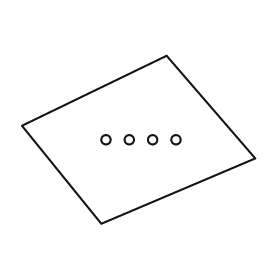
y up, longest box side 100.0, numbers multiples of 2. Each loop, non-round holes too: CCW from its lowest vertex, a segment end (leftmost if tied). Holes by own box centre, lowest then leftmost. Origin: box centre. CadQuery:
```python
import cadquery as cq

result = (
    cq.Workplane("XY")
    .moveTo(-16.0, -36.0)
    .lineTo(50.0, -8.0)
    .lineTo(12.0, 36.0)
    .lineTo(-50.0, 6.0)
    .close()
    .moveTo(-14.0, 0.0)
    .circle(2.0)
    .moveTo(-4.0, 0.0)
    .circle(2.0)
    .moveTo(6.0, 0.0)
    .circle(2.0)
    .moveTo(16.0, 0.0)
    .circle(2.0)
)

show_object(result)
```